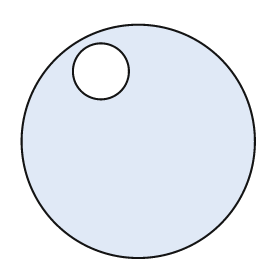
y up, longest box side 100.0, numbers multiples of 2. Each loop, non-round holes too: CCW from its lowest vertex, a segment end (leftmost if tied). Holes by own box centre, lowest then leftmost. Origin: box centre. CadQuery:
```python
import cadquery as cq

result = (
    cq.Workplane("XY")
    .moveTo(0.0, 0.0)
    .circle(50.0)
    .moveTo(-16.0, 30.0)
    .circle(12.0)
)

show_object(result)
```